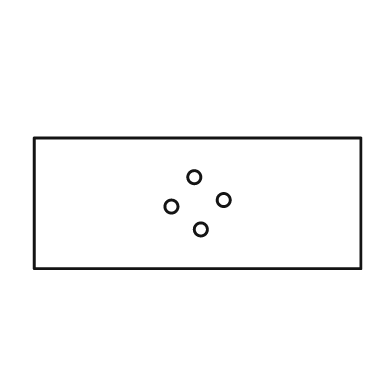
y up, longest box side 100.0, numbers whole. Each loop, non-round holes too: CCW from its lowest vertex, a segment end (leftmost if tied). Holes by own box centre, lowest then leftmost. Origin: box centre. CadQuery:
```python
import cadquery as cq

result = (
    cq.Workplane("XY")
    .moveTo(-50.0, -20.0)
    .lineTo(50.0, -20.0)
    .lineTo(50.0, 20.0)
    .lineTo(-50.0, 20.0)
    .close()
    .moveTo(1.0, -8.0)
    .circle(2.0)
    .moveTo(-8.0, -1.0)
    .circle(2.0)
    .moveTo(8.0, 1.0)
    .circle(2.0)
    .moveTo(-1.0, 8.0)
    .circle(2.0)
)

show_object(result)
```